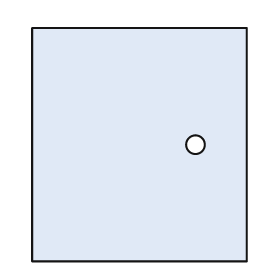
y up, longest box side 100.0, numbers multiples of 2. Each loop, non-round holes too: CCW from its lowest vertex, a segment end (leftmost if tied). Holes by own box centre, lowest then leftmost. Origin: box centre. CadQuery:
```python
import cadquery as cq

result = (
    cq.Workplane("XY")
    .moveTo(-46.0, -50.0)
    .lineTo(46.0, -50.0)
    .lineTo(46.0, 50.0)
    .lineTo(-46.0, 50.0)
    .close()
    .moveTo(24.0, 0.0)
    .circle(4.0)
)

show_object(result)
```